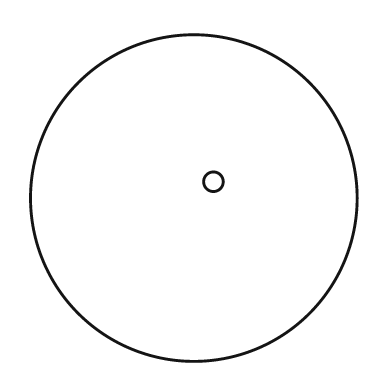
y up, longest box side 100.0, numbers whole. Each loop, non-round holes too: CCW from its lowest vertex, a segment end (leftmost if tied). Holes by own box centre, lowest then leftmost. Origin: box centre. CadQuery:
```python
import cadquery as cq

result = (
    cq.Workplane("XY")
    .moveTo(0.0, 0.0)
    .circle(50.0)
    .moveTo(6.0, 5.0)
    .circle(3.0)
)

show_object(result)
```